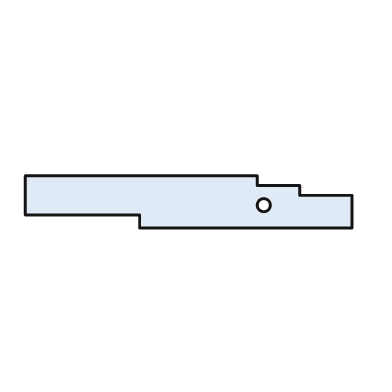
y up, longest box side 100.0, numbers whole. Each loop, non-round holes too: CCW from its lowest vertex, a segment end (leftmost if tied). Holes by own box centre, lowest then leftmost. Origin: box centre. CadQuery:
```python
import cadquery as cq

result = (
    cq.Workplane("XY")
    .moveTo(-15.0, -8.0)
    .lineTo(50.0, -8.0)
    .lineTo(50.0, 2.0)
    .lineTo(34.0, 2.0)
    .lineTo(34.0, 5.0)
    .lineTo(21.0, 5.0)
    .lineTo(21.0, 8.0)
    .lineTo(-50.0, 8.0)
    .lineTo(-50.0, -4.0)
    .lineTo(-15.0, -4.0)
    .close()
    .moveTo(23.0, -1.0)
    .circle(2.0)
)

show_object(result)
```